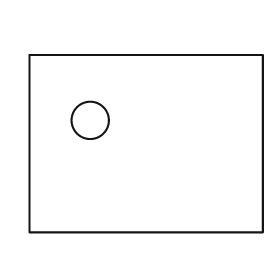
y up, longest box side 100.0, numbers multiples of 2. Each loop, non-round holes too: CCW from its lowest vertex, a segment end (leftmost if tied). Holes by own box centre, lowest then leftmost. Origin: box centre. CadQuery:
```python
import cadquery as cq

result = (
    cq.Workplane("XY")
    .moveTo(-50.0, -38.0)
    .lineTo(50.0, -38.0)
    .lineTo(50.0, 38.0)
    .lineTo(-50.0, 38.0)
    .close()
    .moveTo(-24.0, 10.0)
    .circle(8.0)
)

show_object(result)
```